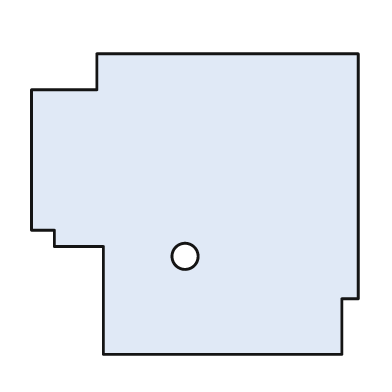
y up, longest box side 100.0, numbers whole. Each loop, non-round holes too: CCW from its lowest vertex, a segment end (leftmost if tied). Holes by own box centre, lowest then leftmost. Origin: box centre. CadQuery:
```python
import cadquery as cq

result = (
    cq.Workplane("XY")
    .moveTo(-28.0, -46.0)
    .lineTo(45.0, -46.0)
    .lineTo(45.0, -29.0)
    .lineTo(50.0, -29.0)
    .lineTo(50.0, 46.0)
    .lineTo(-30.0, 46.0)
    .lineTo(-30.0, 35.0)
    .lineTo(-50.0, 35.0)
    .lineTo(-50.0, -8.0)
    .lineTo(-43.0, -8.0)
    .lineTo(-43.0, -13.0)
    .lineTo(-28.0, -13.0)
    .close()
    .moveTo(-3.0, -16.0)
    .circle(4.0)
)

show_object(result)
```